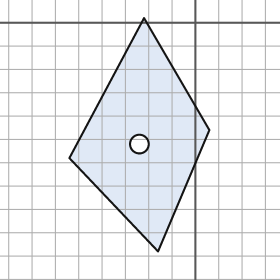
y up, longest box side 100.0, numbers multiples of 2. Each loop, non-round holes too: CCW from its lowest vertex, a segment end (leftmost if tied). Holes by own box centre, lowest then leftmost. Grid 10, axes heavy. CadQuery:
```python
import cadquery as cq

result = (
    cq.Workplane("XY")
    .moveTo(-16.0, -98.0)
    .lineTo(6.0, -46.0)
    .lineTo(-22.0, 2.0)
    .lineTo(-54.0, -58.0)
    .close()
    .moveTo(-24.0, -52.0)
    .circle(4.0)
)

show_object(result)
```